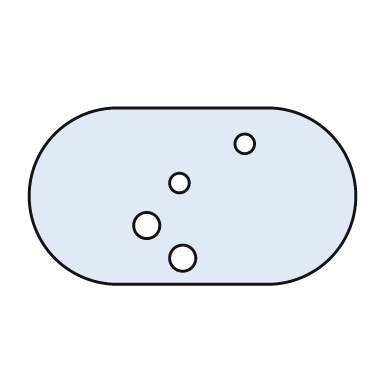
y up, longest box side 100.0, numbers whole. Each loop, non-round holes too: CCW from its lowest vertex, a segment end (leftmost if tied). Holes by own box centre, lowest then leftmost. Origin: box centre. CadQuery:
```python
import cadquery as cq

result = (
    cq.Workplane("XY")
    .moveTo(-23.0, -27.0)
    .lineTo(23.0, -27.0)
    .threePointArc((50.0, 0.0), (23.0, 27.0))
    .lineTo(-23.0, 27.0)
    .threePointArc((-50.0, 0.0), (-23.0, -27.0))
    .close()
    .moveTo(-3.0, -19.0)
    .circle(4.0)
    .moveTo(-14.0, -9.0)
    .circle(4.0)
    .moveTo(-4.0, 4.0)
    .circle(3.0)
    .moveTo(16.0, 16.0)
    .circle(3.0)
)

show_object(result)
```